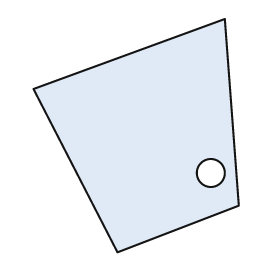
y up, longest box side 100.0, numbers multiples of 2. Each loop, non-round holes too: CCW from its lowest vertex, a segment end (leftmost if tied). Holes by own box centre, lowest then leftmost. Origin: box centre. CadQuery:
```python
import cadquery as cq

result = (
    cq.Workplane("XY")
    .moveTo(-8.0, -50.0)
    .lineTo(44.0, -30.0)
    .lineTo(38.0, 50.0)
    .lineTo(-44.0, 20.0)
    .close()
    .moveTo(32.0, -16.0)
    .circle(6.0)
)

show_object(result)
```